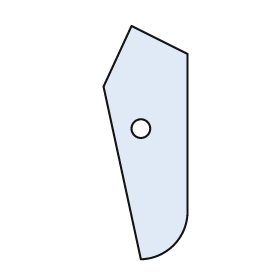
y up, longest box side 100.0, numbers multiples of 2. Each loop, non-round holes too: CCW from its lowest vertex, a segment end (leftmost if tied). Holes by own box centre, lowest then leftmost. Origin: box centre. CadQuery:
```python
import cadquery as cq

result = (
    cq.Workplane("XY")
    .moveTo(-2.0, -50.0)
    .threePointArc((12.0, -44.0), (18.0, -30.0))
    .lineTo(18.0, 38.0)
    .lineTo(-6.0, 50.0)
    .lineTo(-18.0, 24.0)
    .close()
    .moveTo(-2.0, 6.0)
    .circle(4.0)
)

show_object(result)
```